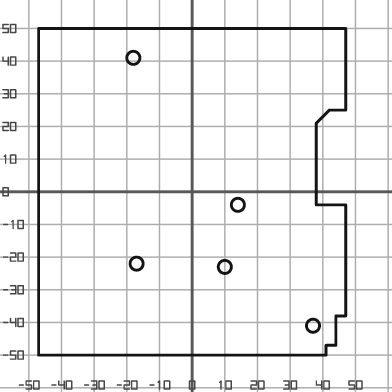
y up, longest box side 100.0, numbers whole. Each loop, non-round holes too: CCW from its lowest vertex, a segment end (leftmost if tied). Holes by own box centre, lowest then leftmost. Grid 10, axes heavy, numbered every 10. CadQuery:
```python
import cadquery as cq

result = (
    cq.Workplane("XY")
    .moveTo(-47.0, -50.0)
    .lineTo(41.0, -50.0)
    .lineTo(41.0, -47.0)
    .lineTo(44.0, -47.0)
    .lineTo(44.0, -38.0)
    .lineTo(47.0, -38.0)
    .lineTo(47.0, -4.0)
    .lineTo(38.0, -4.0)
    .lineTo(38.0, 21.0)
    .lineTo(42.0, 25.0)
    .lineTo(47.0, 25.0)
    .lineTo(47.0, 50.0)
    .lineTo(-47.0, 50.0)
    .close()
    .moveTo(37.0, -41.0)
    .circle(2.0)
    .moveTo(10.0, -23.0)
    .circle(2.0)
    .moveTo(-17.0, -22.0)
    .circle(2.0)
    .moveTo(14.0, -4.0)
    .circle(2.0)
    .moveTo(-18.0, 41.0)
    .circle(2.0)
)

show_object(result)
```